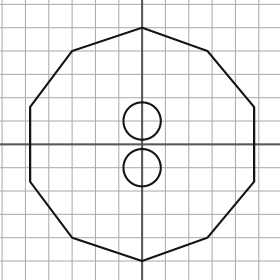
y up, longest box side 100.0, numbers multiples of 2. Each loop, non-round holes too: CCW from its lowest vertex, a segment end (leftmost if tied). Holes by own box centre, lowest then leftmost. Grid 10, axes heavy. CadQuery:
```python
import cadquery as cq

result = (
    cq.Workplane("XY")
    .moveTo(0.0, -50.0)
    .lineTo(28.0, -40.0)
    .lineTo(48.0, -16.0)
    .lineTo(48.0, 16.0)
    .lineTo(28.0, 40.0)
    .lineTo(0.0, 50.0)
    .lineTo(-30.0, 40.0)
    .lineTo(-48.0, 16.0)
    .lineTo(-48.0, -16.0)
    .lineTo(-30.0, -40.0)
    .close()
    .moveTo(0.0, -10.0)
    .circle(8.0)
    .moveTo(0.0, 10.0)
    .circle(8.0)
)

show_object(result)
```